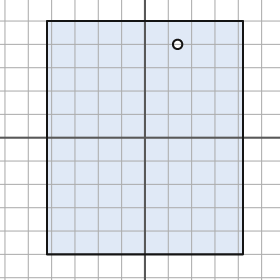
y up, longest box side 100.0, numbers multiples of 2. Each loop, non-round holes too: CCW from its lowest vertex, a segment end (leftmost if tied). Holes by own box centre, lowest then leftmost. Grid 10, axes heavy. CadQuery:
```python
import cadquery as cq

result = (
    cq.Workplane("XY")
    .moveTo(-42.0, -50.0)
    .lineTo(42.0, -50.0)
    .lineTo(42.0, 50.0)
    .lineTo(-42.0, 50.0)
    .close()
    .moveTo(14.0, 40.0)
    .circle(2.0)
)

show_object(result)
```